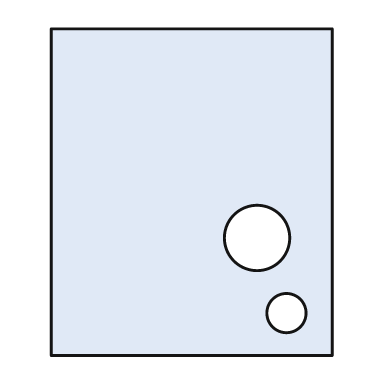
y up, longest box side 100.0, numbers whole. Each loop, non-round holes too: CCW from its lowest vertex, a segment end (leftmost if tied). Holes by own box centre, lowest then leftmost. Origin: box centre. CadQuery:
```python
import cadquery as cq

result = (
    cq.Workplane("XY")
    .moveTo(-43.0, -50.0)
    .lineTo(43.0, -50.0)
    .lineTo(43.0, 50.0)
    .lineTo(-43.0, 50.0)
    .close()
    .moveTo(29.0, -37.0)
    .circle(6.0)
    .moveTo(20.0, -14.0)
    .circle(10.0)
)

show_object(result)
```